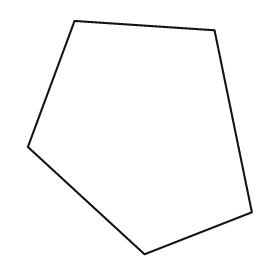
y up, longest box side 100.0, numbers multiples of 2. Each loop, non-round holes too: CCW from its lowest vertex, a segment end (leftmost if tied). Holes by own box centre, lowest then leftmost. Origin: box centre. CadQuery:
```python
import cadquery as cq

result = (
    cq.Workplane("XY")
    .moveTo(2.0, -50.0)
    .lineTo(48.0, -32.0)
    .lineTo(32.0, 46.0)
    .lineTo(-28.0, 50.0)
    .lineTo(-48.0, -4.0)
    .close()
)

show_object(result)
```